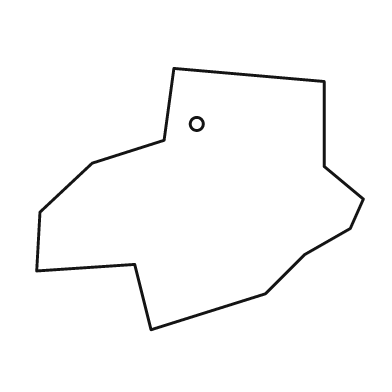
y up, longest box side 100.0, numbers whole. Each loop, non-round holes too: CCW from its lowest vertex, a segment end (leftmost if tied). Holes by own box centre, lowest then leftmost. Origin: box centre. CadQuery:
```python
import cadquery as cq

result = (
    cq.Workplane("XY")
    .moveTo(-15.0, -40.0)
    .lineTo(20.0, -29.0)
    .lineTo(32.0, -17.0)
    .lineTo(46.0, -9.0)
    .lineTo(50.0, 0.0)
    .lineTo(38.0, 10.0)
    .lineTo(38.0, 36.0)
    .lineTo(-8.0, 40.0)
    .lineTo(-11.0, 18.0)
    .lineTo(-33.0, 11.0)
    .lineTo(-49.0, -4.0)
    .lineTo(-50.0, -22.0)
    .lineTo(-20.0, -20.0)
    .close()
    .moveTo(-1.0, 23.0)
    .circle(2.0)
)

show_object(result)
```